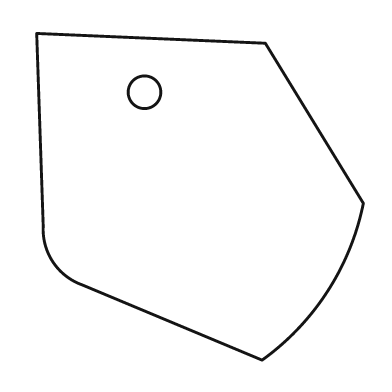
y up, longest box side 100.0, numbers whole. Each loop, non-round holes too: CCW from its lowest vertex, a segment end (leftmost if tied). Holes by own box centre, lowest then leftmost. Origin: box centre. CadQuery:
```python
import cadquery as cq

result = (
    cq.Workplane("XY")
    .moveTo(19.0, -50.0)
    .threePointArc((39.0, -29.0), (50.0, -2.0))
    .lineTo(20.0, 47.0)
    .lineTo(-50.0, 50.0)
    .lineTo(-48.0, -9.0)
    .threePointArc((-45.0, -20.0), (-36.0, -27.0))
    .close()
    .moveTo(-17.0, 32.0)
    .circle(5.0)
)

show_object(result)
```